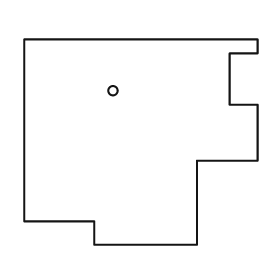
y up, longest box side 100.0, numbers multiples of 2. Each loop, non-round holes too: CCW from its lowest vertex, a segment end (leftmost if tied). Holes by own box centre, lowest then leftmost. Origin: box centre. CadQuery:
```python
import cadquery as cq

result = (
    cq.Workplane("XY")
    .moveTo(-20.0, -44.0)
    .lineTo(24.0, -44.0)
    .lineTo(24.0, -8.0)
    .lineTo(50.0, -8.0)
    .lineTo(50.0, 16.0)
    .lineTo(38.0, 16.0)
    .lineTo(38.0, 38.0)
    .lineTo(50.0, 38.0)
    .lineTo(50.0, 44.0)
    .lineTo(-50.0, 44.0)
    .lineTo(-50.0, -34.0)
    .lineTo(-20.0, -34.0)
    .close()
    .moveTo(-12.0, 22.0)
    .circle(2.0)
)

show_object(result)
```